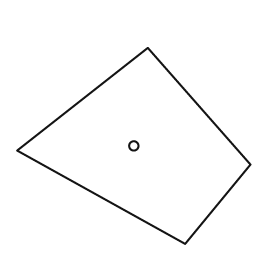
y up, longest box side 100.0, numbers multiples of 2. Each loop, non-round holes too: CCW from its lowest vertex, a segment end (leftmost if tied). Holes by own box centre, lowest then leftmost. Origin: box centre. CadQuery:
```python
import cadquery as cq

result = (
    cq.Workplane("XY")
    .moveTo(22.0, -42.0)
    .lineTo(50.0, -8.0)
    .lineTo(6.0, 42.0)
    .lineTo(-50.0, -2.0)
    .close()
    .moveTo(0.0, 0.0)
    .circle(2.0)
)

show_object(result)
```